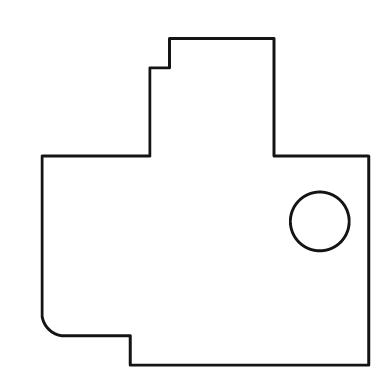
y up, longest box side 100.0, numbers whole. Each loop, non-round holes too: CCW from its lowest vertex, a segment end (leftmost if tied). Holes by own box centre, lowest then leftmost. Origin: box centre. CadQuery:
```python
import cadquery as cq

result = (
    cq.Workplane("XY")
    .moveTo(-23.0, -50.0)
    .lineTo(50.0, -50.0)
    .lineTo(50.0, 14.0)
    .lineTo(21.0, 14.0)
    .lineTo(21.0, 50.0)
    .lineTo(-11.0, 50.0)
    .lineTo(-11.0, 41.0)
    .lineTo(-17.0, 41.0)
    .lineTo(-17.0, 14.0)
    .lineTo(-50.0, 14.0)
    .lineTo(-50.0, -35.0)
    .threePointArc((-48.0, -39.0), (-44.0, -41.0))
    .lineTo(-23.0, -41.0)
    .close()
    .moveTo(35.0, -6.0)
    .circle(9.0)
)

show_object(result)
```